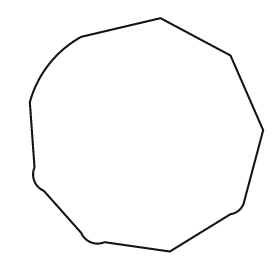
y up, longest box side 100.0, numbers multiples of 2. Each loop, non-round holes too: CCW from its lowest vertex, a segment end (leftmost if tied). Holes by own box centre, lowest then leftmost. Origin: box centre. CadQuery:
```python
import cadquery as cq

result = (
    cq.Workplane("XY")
    .moveTo(10.0, -50.0)
    .lineTo(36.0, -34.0)
    .threePointArc((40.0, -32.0), (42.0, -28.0))
    .lineTo(50.0, 2.0)
    .lineTo(36.0, 34.0)
    .lineTo(6.0, 50.0)
    .lineTo(-28.0, 42.0)
    .threePointArc((-42.0, 30.0), (-50.0, 14.0))
    .lineTo(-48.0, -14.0)
    .threePointArc((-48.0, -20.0), (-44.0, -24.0))
    .lineTo(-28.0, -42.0)
    .threePointArc((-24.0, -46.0), (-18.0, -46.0))
    .close()
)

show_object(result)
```